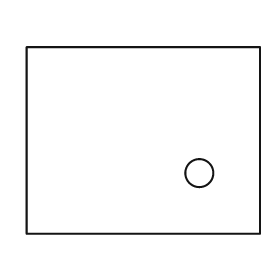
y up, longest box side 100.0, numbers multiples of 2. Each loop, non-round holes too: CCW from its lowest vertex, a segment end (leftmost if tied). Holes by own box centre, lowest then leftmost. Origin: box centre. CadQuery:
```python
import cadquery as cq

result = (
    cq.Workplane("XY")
    .moveTo(-50.0, -40.0)
    .lineTo(50.0, -40.0)
    .lineTo(50.0, 40.0)
    .lineTo(-50.0, 40.0)
    .close()
    .moveTo(24.0, -14.0)
    .circle(6.0)
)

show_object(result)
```